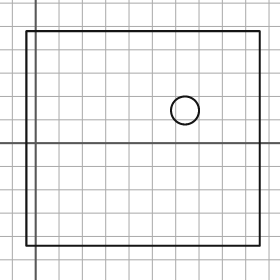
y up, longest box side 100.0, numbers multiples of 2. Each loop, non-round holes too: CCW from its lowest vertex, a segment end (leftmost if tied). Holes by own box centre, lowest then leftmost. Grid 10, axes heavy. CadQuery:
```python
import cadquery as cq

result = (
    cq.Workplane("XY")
    .moveTo(-4.0, -44.0)
    .lineTo(96.0, -44.0)
    .lineTo(96.0, 48.0)
    .lineTo(-4.0, 48.0)
    .close()
    .moveTo(64.0, 14.0)
    .circle(6.0)
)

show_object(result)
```